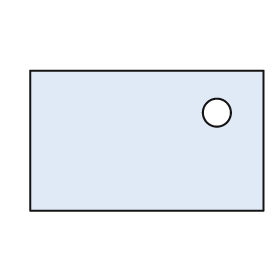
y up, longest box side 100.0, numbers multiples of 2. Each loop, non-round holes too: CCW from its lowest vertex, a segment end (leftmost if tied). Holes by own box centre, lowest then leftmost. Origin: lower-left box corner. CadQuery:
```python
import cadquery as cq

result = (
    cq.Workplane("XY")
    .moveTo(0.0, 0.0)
    .lineTo(100.0, 0.0)
    .lineTo(100.0, 60.0)
    .lineTo(0.0, 60.0)
    .close()
    .moveTo(80.0, 42.0)
    .circle(6.0)
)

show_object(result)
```